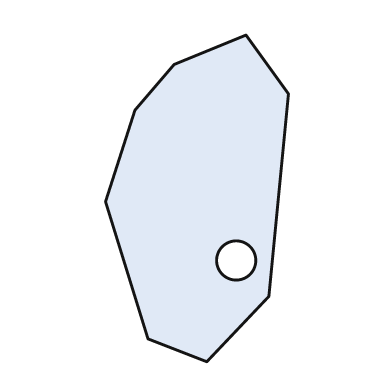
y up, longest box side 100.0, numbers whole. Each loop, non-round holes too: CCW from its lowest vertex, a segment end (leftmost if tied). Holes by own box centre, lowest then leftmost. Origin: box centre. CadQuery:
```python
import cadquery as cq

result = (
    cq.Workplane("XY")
    .moveTo(3.0, -50.0)
    .lineTo(22.0, -30.0)
    .lineTo(28.0, 32.0)
    .lineTo(15.0, 50.0)
    .lineTo(-7.0, 41.0)
    .lineTo(-19.0, 27.0)
    .lineTo(-28.0, -1.0)
    .lineTo(-15.0, -43.0)
    .close()
    .moveTo(12.0, -19.0)
    .circle(6.0)
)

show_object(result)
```